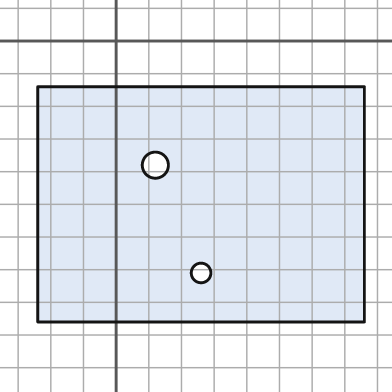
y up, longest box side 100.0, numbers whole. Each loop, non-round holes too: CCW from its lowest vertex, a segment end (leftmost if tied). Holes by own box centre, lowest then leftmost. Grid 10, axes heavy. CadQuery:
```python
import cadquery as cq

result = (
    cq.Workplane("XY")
    .moveTo(-24.0, -86.0)
    .lineTo(76.0, -86.0)
    .lineTo(76.0, -14.0)
    .lineTo(-24.0, -14.0)
    .close()
    .moveTo(26.0, -71.0)
    .circle(3.0)
    .moveTo(12.0, -38.0)
    .circle(4.0)
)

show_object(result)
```